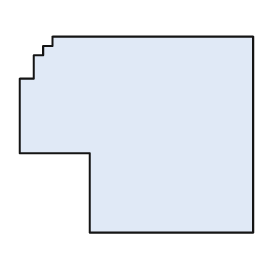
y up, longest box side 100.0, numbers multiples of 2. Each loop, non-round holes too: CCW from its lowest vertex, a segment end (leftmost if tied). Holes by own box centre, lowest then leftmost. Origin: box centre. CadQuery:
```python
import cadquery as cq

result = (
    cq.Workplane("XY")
    .moveTo(-20.0, -42.0)
    .lineTo(50.0, -42.0)
    .lineTo(50.0, 42.0)
    .lineTo(-36.0, 42.0)
    .lineTo(-36.0, 38.0)
    .lineTo(-40.0, 38.0)
    .lineTo(-40.0, 34.0)
    .lineTo(-44.0, 34.0)
    .lineTo(-44.0, 24.0)
    .lineTo(-50.0, 24.0)
    .lineTo(-50.0, -8.0)
    .lineTo(-20.0, -8.0)
    .close()
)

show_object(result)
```